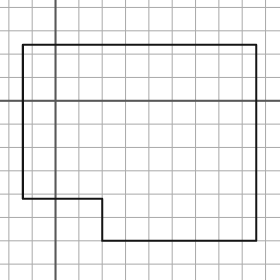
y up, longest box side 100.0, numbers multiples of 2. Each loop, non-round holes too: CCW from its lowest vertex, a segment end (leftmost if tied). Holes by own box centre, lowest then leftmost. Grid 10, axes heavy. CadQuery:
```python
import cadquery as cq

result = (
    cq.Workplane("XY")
    .moveTo(20.0, -60.0)
    .lineTo(86.0, -60.0)
    .lineTo(86.0, 24.0)
    .lineTo(-14.0, 24.0)
    .lineTo(-14.0, -42.0)
    .lineTo(20.0, -42.0)
    .close()
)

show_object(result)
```